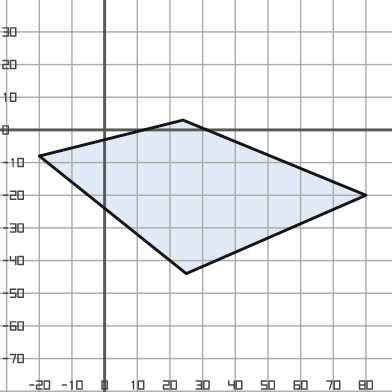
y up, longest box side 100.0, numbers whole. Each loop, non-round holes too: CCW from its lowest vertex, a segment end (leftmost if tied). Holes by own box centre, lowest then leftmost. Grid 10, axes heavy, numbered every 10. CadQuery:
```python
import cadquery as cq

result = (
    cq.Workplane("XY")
    .moveTo(25.0, -44.0)
    .lineTo(80.0, -20.0)
    .lineTo(24.0, 3.0)
    .lineTo(-20.0, -8.0)
    .close()
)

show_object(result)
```